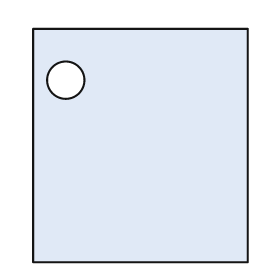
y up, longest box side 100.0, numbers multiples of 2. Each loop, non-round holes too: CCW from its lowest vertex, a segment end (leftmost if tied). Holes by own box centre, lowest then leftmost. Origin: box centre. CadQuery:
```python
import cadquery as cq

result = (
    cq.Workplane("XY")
    .moveTo(-46.0, -50.0)
    .lineTo(46.0, -50.0)
    .lineTo(46.0, 50.0)
    .lineTo(-46.0, 50.0)
    .close()
    .moveTo(-32.0, 28.0)
    .circle(8.0)
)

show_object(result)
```